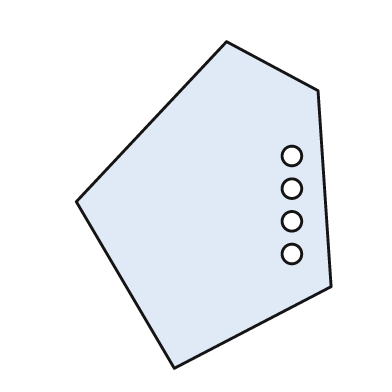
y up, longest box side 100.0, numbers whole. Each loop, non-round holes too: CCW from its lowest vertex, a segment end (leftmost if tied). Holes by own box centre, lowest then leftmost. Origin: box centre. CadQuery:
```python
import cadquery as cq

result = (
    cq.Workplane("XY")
    .moveTo(-9.0, -50.0)
    .lineTo(39.0, -25.0)
    .lineTo(35.0, 35.0)
    .lineTo(7.0, 50.0)
    .lineTo(-39.0, 1.0)
    .close()
    .moveTo(27.0, -15.0)
    .circle(3.0)
    .moveTo(27.0, -5.0)
    .circle(3.0)
    .moveTo(27.0, 5.0)
    .circle(3.0)
    .moveTo(27.0, 15.0)
    .circle(3.0)
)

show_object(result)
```